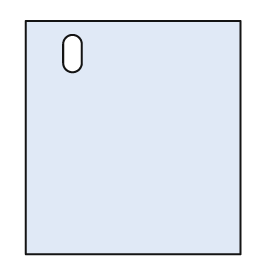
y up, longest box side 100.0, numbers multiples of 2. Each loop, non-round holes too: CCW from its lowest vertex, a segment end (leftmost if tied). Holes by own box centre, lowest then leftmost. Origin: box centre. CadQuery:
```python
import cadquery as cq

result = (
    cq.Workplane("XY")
    .moveTo(-46.0, -50.0)
    .lineTo(46.0, -50.0)
    .lineTo(46.0, 50.0)
    .lineTo(-46.0, 50.0)
    .close()
    .moveTo(-30.0, 32.0)
    .threePointArc((-26.0, 28.0), (-22.0, 32.0))
    .lineTo(-22.0, 40.0)
    .threePointArc((-26.0, 44.0), (-30.0, 40.0))
    .close()
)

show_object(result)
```